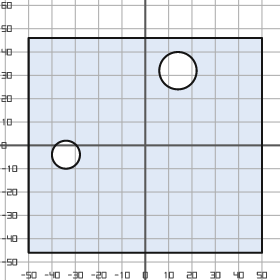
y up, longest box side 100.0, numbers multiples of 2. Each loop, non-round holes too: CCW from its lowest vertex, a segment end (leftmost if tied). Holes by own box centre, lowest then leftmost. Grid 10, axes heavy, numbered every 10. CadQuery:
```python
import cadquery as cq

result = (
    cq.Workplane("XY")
    .moveTo(-50.0, -46.0)
    .lineTo(50.0, -46.0)
    .lineTo(50.0, 46.0)
    .lineTo(-50.0, 46.0)
    .close()
    .moveTo(-34.0, -4.0)
    .circle(6.0)
    .moveTo(14.0, 32.0)
    .circle(8.0)
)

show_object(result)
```